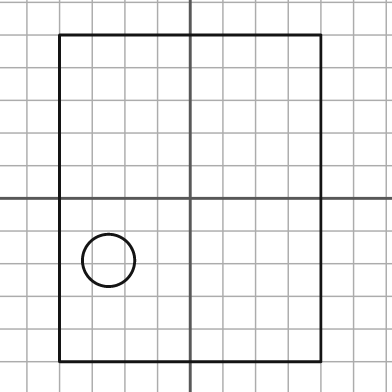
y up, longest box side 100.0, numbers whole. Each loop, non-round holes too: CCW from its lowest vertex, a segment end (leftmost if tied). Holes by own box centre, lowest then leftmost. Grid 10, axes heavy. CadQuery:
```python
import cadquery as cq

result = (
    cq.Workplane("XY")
    .moveTo(-40.0, -50.0)
    .lineTo(40.0, -50.0)
    .lineTo(40.0, 50.0)
    .lineTo(-40.0, 50.0)
    .close()
    .moveTo(-25.0, -19.0)
    .circle(8.0)
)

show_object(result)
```